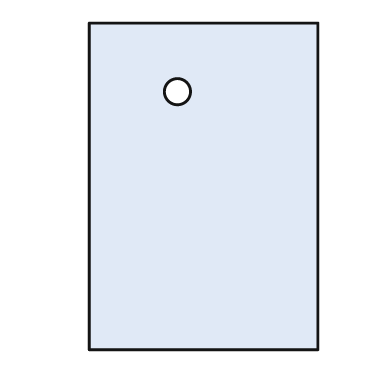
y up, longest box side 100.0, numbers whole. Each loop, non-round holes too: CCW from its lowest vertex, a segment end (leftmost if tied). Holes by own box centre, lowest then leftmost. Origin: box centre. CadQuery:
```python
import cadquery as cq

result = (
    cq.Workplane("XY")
    .moveTo(-35.0, -50.0)
    .lineTo(35.0, -50.0)
    .lineTo(35.0, 50.0)
    .lineTo(-35.0, 50.0)
    .close()
    .moveTo(-8.0, 29.0)
    .circle(4.0)
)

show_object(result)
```